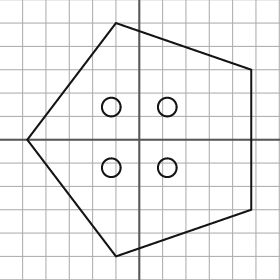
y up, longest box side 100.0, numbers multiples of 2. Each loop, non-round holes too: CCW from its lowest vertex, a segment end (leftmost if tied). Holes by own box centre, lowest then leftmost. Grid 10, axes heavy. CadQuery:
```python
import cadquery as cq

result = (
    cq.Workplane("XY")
    .moveTo(-10.0, -50.0)
    .lineTo(48.0, -30.0)
    .lineTo(48.0, 30.0)
    .lineTo(-10.0, 50.0)
    .lineTo(-48.0, 0.0)
    .close()
    .moveTo(-12.0, -12.0)
    .circle(4.0)
    .moveTo(12.0, -12.0)
    .circle(4.0)
    .moveTo(-12.0, 14.0)
    .circle(4.0)
    .moveTo(12.0, 14.0)
    .circle(4.0)
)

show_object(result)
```